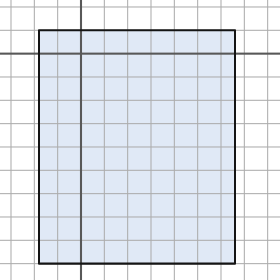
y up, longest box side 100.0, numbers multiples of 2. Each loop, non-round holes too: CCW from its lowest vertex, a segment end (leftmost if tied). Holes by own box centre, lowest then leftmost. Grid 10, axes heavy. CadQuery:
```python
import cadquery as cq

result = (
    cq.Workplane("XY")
    .moveTo(-18.0, -90.0)
    .lineTo(66.0, -90.0)
    .lineTo(66.0, 10.0)
    .lineTo(-18.0, 10.0)
    .close()
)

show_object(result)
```